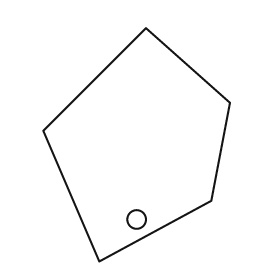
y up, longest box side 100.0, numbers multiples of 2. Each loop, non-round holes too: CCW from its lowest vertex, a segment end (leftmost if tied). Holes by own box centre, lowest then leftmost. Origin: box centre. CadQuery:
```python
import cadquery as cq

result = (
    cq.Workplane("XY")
    .moveTo(-16.0, -50.0)
    .lineTo(32.0, -24.0)
    .lineTo(40.0, 18.0)
    .lineTo(4.0, 50.0)
    .lineTo(-40.0, 6.0)
    .close()
    .moveTo(0.0, -32.0)
    .circle(4.0)
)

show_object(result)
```